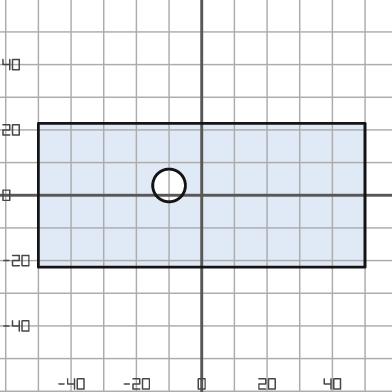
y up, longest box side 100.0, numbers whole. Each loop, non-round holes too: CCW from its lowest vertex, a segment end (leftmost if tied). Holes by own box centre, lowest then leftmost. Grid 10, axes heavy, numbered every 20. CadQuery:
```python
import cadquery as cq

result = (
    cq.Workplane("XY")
    .moveTo(-50.0, -22.0)
    .lineTo(50.0, -22.0)
    .lineTo(50.0, 22.0)
    .lineTo(-50.0, 22.0)
    .close()
    .moveTo(-10.0, 3.0)
    .circle(5.0)
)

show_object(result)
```